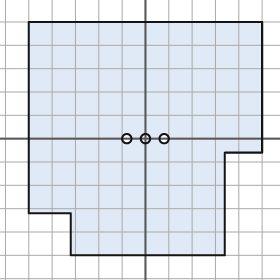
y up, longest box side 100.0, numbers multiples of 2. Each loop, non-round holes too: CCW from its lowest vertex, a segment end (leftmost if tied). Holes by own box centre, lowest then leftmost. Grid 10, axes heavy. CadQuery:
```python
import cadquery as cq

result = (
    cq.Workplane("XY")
    .moveTo(-32.0, -50.0)
    .lineTo(34.0, -50.0)
    .lineTo(34.0, -6.0)
    .lineTo(50.0, -6.0)
    .lineTo(50.0, 50.0)
    .lineTo(-50.0, 50.0)
    .lineTo(-50.0, -32.0)
    .lineTo(-32.0, -32.0)
    .close()
    .moveTo(-8.0, 0.0)
    .circle(2.0)
    .moveTo(0.0, 0.0)
    .circle(2.0)
    .moveTo(8.0, 0.0)
    .circle(2.0)
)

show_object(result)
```